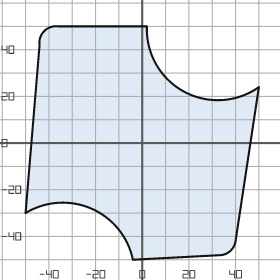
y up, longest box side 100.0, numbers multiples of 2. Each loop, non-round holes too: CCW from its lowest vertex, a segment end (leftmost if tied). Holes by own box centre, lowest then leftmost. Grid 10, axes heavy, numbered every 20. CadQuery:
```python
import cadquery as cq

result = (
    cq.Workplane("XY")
    .moveTo(-4.0, -50.0)
    .lineTo(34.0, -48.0)
    .threePointArc((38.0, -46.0), (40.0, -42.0))
    .lineTo(50.0, 24.0)
    .threePointArc((18.0, 22.0), (2.0, 50.0))
    .lineTo(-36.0, 50.0)
    .threePointArc((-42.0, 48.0), (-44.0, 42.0))
    .lineTo(-50.0, -30.0)
    .threePointArc((-22.0, -28.0), (-4.0, -50.0))
    .close()
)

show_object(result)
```